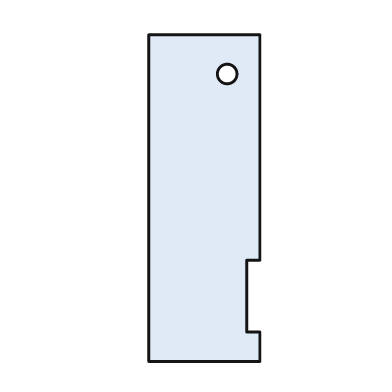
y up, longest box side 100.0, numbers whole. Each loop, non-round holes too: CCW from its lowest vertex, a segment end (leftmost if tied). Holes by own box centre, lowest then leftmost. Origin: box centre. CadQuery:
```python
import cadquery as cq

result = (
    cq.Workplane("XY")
    .moveTo(-17.0, -50.0)
    .lineTo(17.0, -50.0)
    .lineTo(17.0, -41.0)
    .lineTo(13.0, -41.0)
    .lineTo(13.0, -19.0)
    .lineTo(17.0, -19.0)
    .lineTo(17.0, 50.0)
    .lineTo(-17.0, 50.0)
    .close()
    .moveTo(7.0, 38.0)
    .circle(3.0)
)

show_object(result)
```